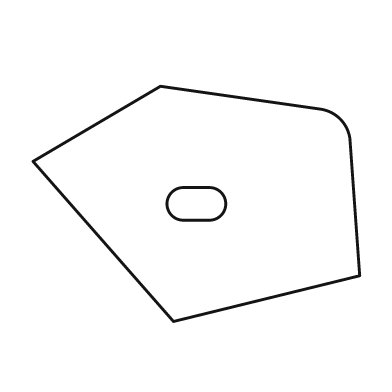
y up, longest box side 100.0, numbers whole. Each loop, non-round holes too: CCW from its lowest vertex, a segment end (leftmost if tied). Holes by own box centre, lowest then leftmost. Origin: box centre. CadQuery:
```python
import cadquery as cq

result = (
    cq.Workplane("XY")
    .moveTo(-7.0, -36.0)
    .lineTo(50.0, -22.0)
    .lineTo(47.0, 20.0)
    .threePointArc((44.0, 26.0), (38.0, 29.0))
    .lineTo(-11.0, 36.0)
    .lineTo(-50.0, 13.0)
    .close()
    .moveTo(-4.0, -5.0)
    .lineTo(4.0, -5.0)
    .threePointArc((9.0, 0.0), (4.0, 5.0))
    .lineTo(-4.0, 5.0)
    .threePointArc((-9.0, 0.0), (-4.0, -5.0))
    .close()
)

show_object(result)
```